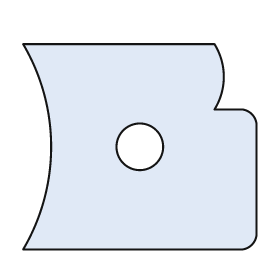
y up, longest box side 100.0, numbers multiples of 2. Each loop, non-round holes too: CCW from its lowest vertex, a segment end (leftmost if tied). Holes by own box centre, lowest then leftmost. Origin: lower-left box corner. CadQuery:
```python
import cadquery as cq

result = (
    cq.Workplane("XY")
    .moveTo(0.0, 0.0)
    .lineTo(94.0, 0.0)
    .threePointArc((98.0, 2.0), (100.0, 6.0))
    .lineTo(100.0, 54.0)
    .threePointArc((98.0, 58.0), (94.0, 60.0))
    .lineTo(82.0, 60.0)
    .threePointArc((86.0, 74.0), (82.0, 88.0))
    .lineTo(0.0, 88.0)
    .threePointArc((12.0, 44.0), (0.0, 0.0))
    .close()
    .moveTo(50.0, 44.0)
    .circle(10.0)
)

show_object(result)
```